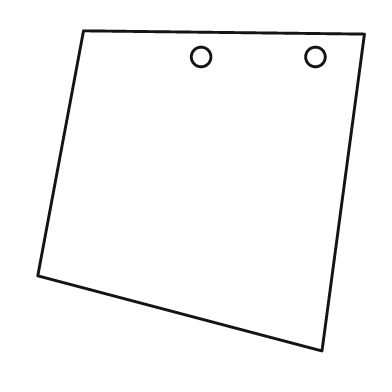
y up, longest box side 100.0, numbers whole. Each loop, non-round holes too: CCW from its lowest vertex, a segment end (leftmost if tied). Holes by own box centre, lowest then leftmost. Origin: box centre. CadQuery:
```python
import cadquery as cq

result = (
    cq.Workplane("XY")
    .moveTo(37.0, -49.0)
    .lineTo(50.0, 48.0)
    .lineTo(-36.0, 49.0)
    .lineTo(-50.0, -26.0)
    .close()
    .moveTo(0.0, 41.0)
    .circle(3.0)
    .moveTo(35.0, 41.0)
    .circle(3.0)
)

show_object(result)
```